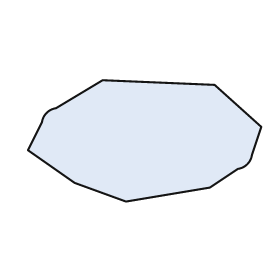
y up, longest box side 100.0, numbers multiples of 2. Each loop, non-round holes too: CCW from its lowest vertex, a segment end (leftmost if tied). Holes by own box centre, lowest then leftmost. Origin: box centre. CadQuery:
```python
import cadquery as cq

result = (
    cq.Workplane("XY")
    .moveTo(-8.0, -26.0)
    .lineTo(28.0, -20.0)
    .lineTo(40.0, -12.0)
    .threePointArc((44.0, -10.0), (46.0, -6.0))
    .lineTo(50.0, 6.0)
    .lineTo(30.0, 24.0)
    .lineTo(-18.0, 26.0)
    .lineTo(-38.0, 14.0)
    .threePointArc((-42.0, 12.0), (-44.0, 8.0))
    .lineTo(-50.0, -4.0)
    .lineTo(-30.0, -18.0)
    .close()
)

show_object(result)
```